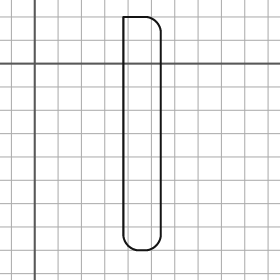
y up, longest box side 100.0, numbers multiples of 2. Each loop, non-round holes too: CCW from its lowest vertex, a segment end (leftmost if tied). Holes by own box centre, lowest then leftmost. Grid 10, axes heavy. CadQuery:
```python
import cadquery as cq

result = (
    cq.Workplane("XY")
    .moveTo(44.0, -80.0)
    .lineTo(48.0, -80.0)
    .threePointArc((52.0, -78.0), (54.0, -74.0))
    .lineTo(54.0, 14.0)
    .threePointArc((52.0, 18.0), (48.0, 20.0))
    .lineTo(38.0, 20.0)
    .lineTo(38.0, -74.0)
    .threePointArc((40.0, -78.0), (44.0, -80.0))
    .close()
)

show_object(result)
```